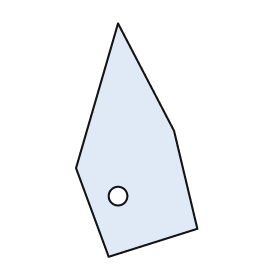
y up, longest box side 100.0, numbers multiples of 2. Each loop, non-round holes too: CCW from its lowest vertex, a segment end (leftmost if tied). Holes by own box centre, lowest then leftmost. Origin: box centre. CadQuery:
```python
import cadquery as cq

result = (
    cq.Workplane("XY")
    .moveTo(-12.0, -50.0)
    .lineTo(26.0, -38.0)
    .lineTo(16.0, 4.0)
    .lineTo(-8.0, 50.0)
    .lineTo(-26.0, -12.0)
    .close()
    .moveTo(-8.0, -24.0)
    .circle(4.0)
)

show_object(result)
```